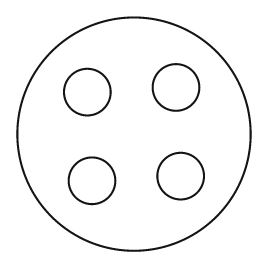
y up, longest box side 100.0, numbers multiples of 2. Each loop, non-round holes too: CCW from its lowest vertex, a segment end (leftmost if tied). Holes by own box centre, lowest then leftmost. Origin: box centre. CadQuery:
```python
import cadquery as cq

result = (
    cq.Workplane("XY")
    .moveTo(0.0, 0.0)
    .circle(50.0)
    .moveTo(-18.0, -20.0)
    .circle(10.0)
    .moveTo(20.0, -18.0)
    .circle(10.0)
    .moveTo(-20.0, 18.0)
    .circle(10.0)
    .moveTo(18.0, 20.0)
    .circle(10.0)
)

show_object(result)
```